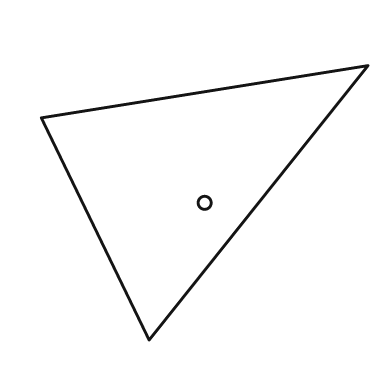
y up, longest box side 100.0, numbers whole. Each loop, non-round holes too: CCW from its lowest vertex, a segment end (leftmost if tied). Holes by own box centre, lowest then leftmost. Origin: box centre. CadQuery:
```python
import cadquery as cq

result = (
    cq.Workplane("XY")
    .moveTo(-17.0, -42.0)
    .lineTo(50.0, 42.0)
    .lineTo(-50.0, 26.0)
    .close()
    .moveTo(0.0, 0.0)
    .circle(2.0)
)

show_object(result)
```